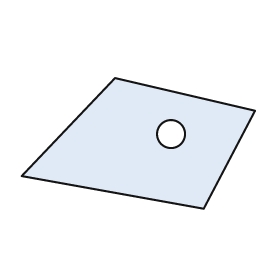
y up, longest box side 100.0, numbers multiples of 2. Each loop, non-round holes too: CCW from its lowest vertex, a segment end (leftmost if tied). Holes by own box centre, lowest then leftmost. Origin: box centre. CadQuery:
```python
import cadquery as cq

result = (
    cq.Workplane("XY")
    .moveTo(28.0, -28.0)
    .lineTo(50.0, 14.0)
    .lineTo(-10.0, 28.0)
    .lineTo(-50.0, -14.0)
    .close()
    .moveTo(14.0, 4.0)
    .circle(6.0)
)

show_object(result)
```